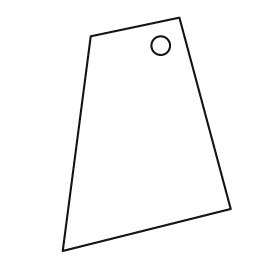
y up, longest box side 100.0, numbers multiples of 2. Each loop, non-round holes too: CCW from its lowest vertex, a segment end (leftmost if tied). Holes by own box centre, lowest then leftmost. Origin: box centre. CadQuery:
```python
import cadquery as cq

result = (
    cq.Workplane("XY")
    .moveTo(-36.0, -50.0)
    .lineTo(36.0, -32.0)
    .lineTo(14.0, 50.0)
    .lineTo(-24.0, 42.0)
    .close()
    .moveTo(6.0, 38.0)
    .circle(4.0)
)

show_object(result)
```